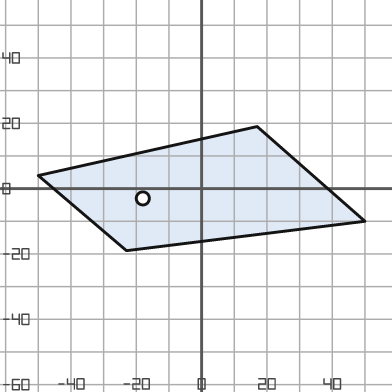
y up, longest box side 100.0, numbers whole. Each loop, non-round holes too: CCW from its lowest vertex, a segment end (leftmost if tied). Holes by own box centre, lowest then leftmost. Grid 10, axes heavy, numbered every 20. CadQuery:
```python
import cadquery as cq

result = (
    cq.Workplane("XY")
    .moveTo(-23.0, -19.0)
    .lineTo(50.0, -10.0)
    .lineTo(17.0, 19.0)
    .lineTo(-50.0, 4.0)
    .close()
    .moveTo(-18.0, -3.0)
    .circle(2.0)
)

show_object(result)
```